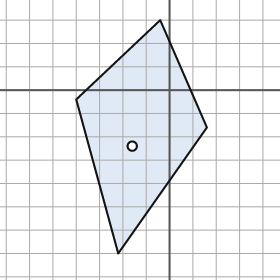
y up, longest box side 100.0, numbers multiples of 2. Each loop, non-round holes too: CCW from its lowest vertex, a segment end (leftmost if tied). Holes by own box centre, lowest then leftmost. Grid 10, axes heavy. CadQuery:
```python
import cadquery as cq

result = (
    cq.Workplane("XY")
    .moveTo(-22.0, -70.0)
    .lineTo(16.0, -16.0)
    .lineTo(-4.0, 30.0)
    .lineTo(-40.0, -4.0)
    .close()
    .moveTo(-16.0, -24.0)
    .circle(2.0)
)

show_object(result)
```